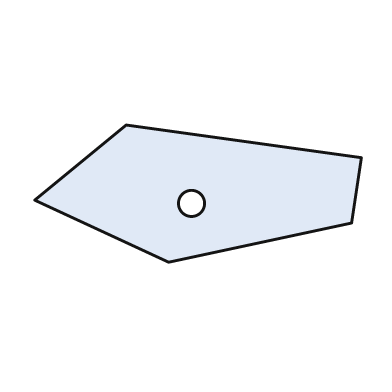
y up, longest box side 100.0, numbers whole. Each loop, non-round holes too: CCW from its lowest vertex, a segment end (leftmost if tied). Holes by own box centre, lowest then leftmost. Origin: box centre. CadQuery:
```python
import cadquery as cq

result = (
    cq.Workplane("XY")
    .moveTo(-9.0, -21.0)
    .lineTo(47.0, -9.0)
    .lineTo(50.0, 11.0)
    .lineTo(-22.0, 21.0)
    .lineTo(-50.0, -2.0)
    .close()
    .moveTo(-2.0, -3.0)
    .circle(4.0)
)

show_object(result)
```